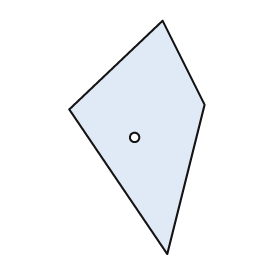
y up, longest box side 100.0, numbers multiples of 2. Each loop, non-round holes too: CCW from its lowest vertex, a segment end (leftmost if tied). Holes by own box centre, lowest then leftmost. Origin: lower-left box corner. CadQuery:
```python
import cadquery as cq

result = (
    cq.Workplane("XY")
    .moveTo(42.0, 0.0)
    .lineTo(58.0, 64.0)
    .lineTo(40.0, 100.0)
    .lineTo(0.0, 62.0)
    .close()
    .moveTo(28.0, 50.0)
    .circle(2.0)
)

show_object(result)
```